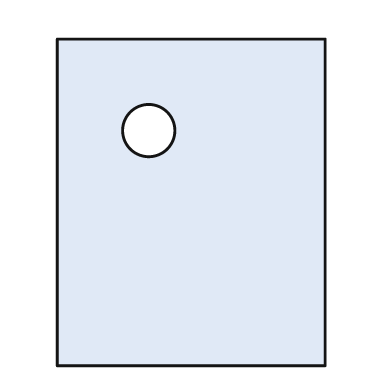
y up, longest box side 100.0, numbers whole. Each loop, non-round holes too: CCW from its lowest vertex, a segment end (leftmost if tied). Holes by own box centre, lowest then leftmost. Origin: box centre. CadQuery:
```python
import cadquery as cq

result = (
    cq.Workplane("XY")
    .moveTo(-41.0, -50.0)
    .lineTo(41.0, -50.0)
    .lineTo(41.0, 50.0)
    .lineTo(-41.0, 50.0)
    .close()
    .moveTo(-13.0, 22.0)
    .circle(8.0)
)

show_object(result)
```